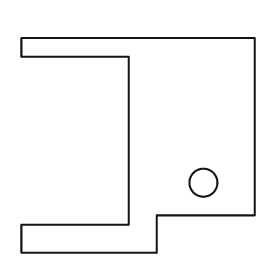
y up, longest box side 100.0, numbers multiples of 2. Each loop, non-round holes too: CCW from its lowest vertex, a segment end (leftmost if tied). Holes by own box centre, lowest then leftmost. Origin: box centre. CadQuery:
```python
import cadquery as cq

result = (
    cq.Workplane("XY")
    .moveTo(-50.0, -46.0)
    .lineTo(8.0, -46.0)
    .lineTo(8.0, -30.0)
    .lineTo(50.0, -30.0)
    .lineTo(50.0, 46.0)
    .lineTo(-50.0, 46.0)
    .lineTo(-50.0, 38.0)
    .lineTo(-4.0, 38.0)
    .lineTo(-4.0, -34.0)
    .lineTo(-50.0, -34.0)
    .close()
    .moveTo(28.0, -16.0)
    .circle(6.0)
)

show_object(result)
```